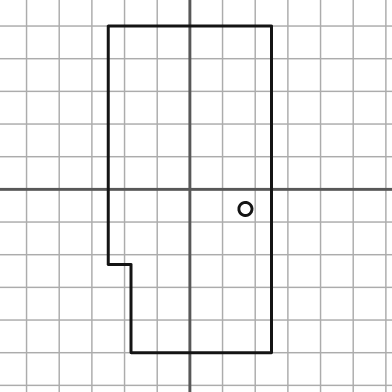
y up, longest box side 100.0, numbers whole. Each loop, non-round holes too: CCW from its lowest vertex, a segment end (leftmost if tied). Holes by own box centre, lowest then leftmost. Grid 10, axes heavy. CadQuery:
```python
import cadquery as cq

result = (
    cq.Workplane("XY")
    .moveTo(-18.0, -50.0)
    .lineTo(25.0, -50.0)
    .lineTo(25.0, 50.0)
    .lineTo(-25.0, 50.0)
    .lineTo(-25.0, -23.0)
    .lineTo(-18.0, -23.0)
    .close()
    .moveTo(17.0, -6.0)
    .circle(2.0)
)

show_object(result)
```